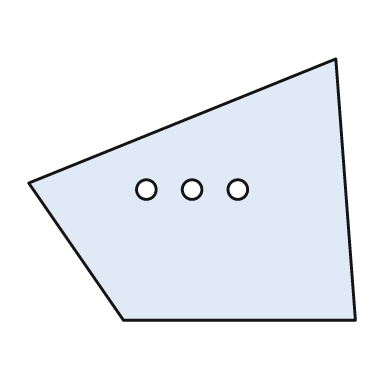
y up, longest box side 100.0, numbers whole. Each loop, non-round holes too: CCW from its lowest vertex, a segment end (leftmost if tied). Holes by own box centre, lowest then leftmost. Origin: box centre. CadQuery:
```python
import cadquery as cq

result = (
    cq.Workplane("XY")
    .moveTo(-21.0, -40.0)
    .lineTo(50.0, -40.0)
    .lineTo(44.0, 40.0)
    .lineTo(-50.0, 2.0)
    .close()
    .moveTo(-14.0, 0.0)
    .circle(3.0)
    .moveTo(0.0, 0.0)
    .circle(3.0)
    .moveTo(14.0, 0.0)
    .circle(3.0)
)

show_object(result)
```